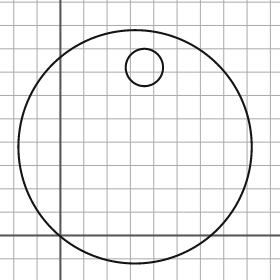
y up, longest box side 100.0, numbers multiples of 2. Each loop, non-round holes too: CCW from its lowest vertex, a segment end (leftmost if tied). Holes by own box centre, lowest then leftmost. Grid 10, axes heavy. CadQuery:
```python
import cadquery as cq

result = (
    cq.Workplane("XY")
    .moveTo(32.0, 38.0)
    .circle(50.0)
    .moveTo(36.0, 72.0)
    .circle(8.0)
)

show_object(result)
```